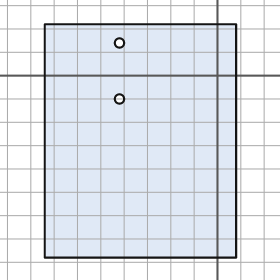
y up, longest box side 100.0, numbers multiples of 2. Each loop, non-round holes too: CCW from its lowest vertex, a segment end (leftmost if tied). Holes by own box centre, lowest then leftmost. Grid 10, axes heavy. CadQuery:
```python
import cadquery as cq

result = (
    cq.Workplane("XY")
    .moveTo(-74.0, -78.0)
    .lineTo(8.0, -78.0)
    .lineTo(8.0, 22.0)
    .lineTo(-74.0, 22.0)
    .close()
    .moveTo(-42.0, -10.0)
    .circle(2.0)
    .moveTo(-42.0, 14.0)
    .circle(2.0)
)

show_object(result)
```